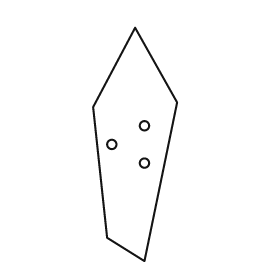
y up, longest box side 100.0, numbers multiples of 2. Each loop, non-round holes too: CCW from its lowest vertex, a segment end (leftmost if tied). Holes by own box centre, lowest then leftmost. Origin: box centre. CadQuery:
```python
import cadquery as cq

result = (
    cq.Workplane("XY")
    .moveTo(4.0, -50.0)
    .lineTo(18.0, 18.0)
    .lineTo(0.0, 50.0)
    .lineTo(-18.0, 16.0)
    .lineTo(-12.0, -40.0)
    .close()
    .moveTo(4.0, -8.0)
    .circle(2.0)
    .moveTo(-10.0, 0.0)
    .circle(2.0)
    .moveTo(4.0, 8.0)
    .circle(2.0)
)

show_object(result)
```